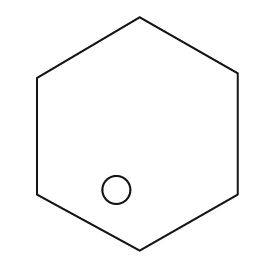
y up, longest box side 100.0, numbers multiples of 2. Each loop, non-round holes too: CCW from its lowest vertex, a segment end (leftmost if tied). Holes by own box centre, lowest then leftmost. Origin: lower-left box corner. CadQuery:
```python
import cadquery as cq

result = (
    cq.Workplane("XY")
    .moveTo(44.0, 0.0)
    .lineTo(86.0, 24.0)
    .lineTo(86.0, 76.0)
    .lineTo(44.0, 100.0)
    .lineTo(0.0, 74.0)
    .lineTo(0.0, 24.0)
    .close()
    .moveTo(34.0, 26.0)
    .circle(6.0)
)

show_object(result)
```